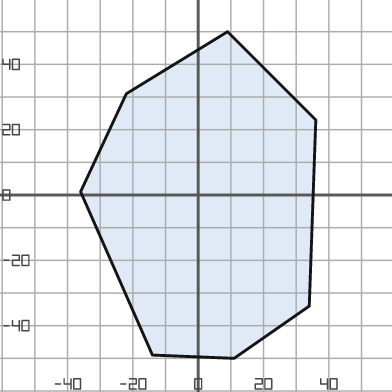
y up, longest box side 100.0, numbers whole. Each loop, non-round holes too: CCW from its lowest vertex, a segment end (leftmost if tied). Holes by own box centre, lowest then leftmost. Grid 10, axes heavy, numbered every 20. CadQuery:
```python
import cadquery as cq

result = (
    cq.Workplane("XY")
    .moveTo(11.0, -50.0)
    .lineTo(34.0, -34.0)
    .lineTo(36.0, 23.0)
    .lineTo(9.0, 50.0)
    .lineTo(-22.0, 31.0)
    .lineTo(-36.0, 1.0)
    .lineTo(-14.0, -49.0)
    .close()
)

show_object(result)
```